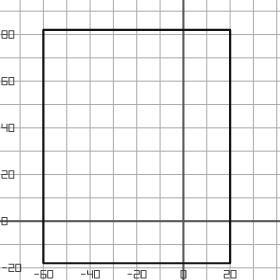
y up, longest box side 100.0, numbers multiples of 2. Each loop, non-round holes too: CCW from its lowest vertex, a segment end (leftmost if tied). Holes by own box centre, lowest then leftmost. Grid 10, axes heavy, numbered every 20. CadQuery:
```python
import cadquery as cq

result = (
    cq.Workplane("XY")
    .moveTo(-60.0, -18.0)
    .lineTo(20.0, -18.0)
    .lineTo(20.0, 82.0)
    .lineTo(-60.0, 82.0)
    .close()
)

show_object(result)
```